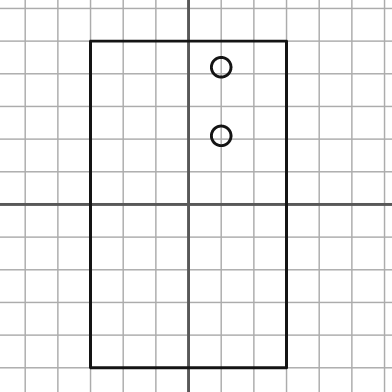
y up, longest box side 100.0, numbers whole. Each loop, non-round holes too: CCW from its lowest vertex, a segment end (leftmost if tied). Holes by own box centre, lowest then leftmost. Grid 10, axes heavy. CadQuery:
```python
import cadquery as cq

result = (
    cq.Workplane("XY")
    .moveTo(-30.0, -50.0)
    .lineTo(30.0, -50.0)
    .lineTo(30.0, 50.0)
    .lineTo(-30.0, 50.0)
    .close()
    .moveTo(10.0, 21.0)
    .circle(3.0)
    .moveTo(10.0, 42.0)
    .circle(3.0)
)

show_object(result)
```